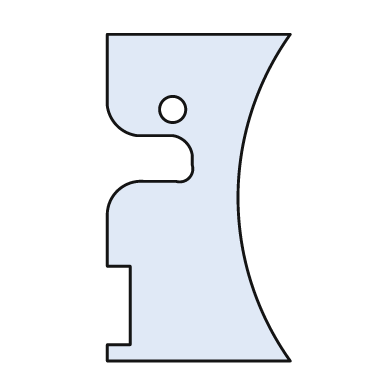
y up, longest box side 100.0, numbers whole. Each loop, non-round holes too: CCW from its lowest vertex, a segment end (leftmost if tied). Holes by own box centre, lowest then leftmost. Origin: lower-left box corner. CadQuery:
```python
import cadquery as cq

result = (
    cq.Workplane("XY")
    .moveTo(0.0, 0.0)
    .lineTo(56.0, 0.0)
    .threePointArc((40.0, 50.0), (56.0, 100.0))
    .lineTo(0.0, 100.0)
    .lineTo(0.0, 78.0)
    .threePointArc((3.0, 72.0), (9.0, 69.0))
    .lineTo(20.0, 69.0)
    .threePointArc((24.0, 67.0), (26.0, 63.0))
    .lineTo(26.0, 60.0)
    .threePointArc((25.0, 56.0), (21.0, 55.0))
    .lineTo(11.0, 55.0)
    .threePointArc((3.0, 52.0), (0.0, 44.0))
    .lineTo(0.0, 29.0)
    .lineTo(7.0, 29.0)
    .lineTo(7.0, 5.0)
    .lineTo(0.0, 5.0)
    .close()
    .moveTo(20.0, 77.0)
    .circle(4.0)
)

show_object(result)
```